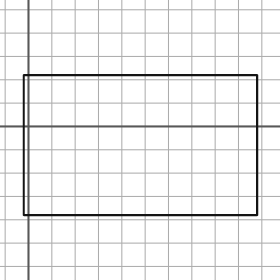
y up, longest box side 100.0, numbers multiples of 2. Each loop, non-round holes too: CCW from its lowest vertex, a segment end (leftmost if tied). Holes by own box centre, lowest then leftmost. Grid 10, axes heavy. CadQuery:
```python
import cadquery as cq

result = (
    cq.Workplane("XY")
    .moveTo(-2.0, -38.0)
    .lineTo(98.0, -38.0)
    .lineTo(98.0, 22.0)
    .lineTo(-2.0, 22.0)
    .close()
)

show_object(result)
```